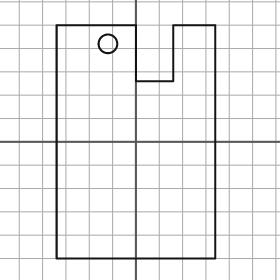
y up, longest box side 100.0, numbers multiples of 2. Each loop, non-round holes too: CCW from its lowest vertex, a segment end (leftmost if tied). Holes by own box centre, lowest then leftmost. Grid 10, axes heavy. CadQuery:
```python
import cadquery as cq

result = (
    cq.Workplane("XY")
    .moveTo(-34.0, -50.0)
    .lineTo(34.0, -50.0)
    .lineTo(34.0, 50.0)
    .lineTo(16.0, 50.0)
    .lineTo(16.0, 26.0)
    .lineTo(0.0, 26.0)
    .lineTo(0.0, 50.0)
    .lineTo(-34.0, 50.0)
    .close()
    .moveTo(-12.0, 42.0)
    .circle(4.0)
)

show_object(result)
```